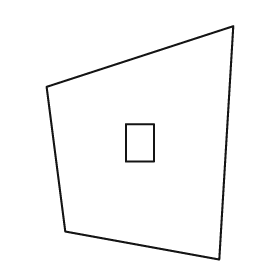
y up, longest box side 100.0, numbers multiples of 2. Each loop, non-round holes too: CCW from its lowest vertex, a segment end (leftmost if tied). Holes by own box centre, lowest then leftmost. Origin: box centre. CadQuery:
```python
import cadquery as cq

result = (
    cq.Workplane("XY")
    .moveTo(34.0, -50.0)
    .lineTo(40.0, 50.0)
    .lineTo(-40.0, 24.0)
    .lineTo(-32.0, -38.0)
    .close()
    .moveTo(-6.0, -8.0)
    .lineTo(6.0, -8.0)
    .lineTo(6.0, 8.0)
    .lineTo(-6.0, 8.0)
    .close()
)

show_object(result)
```